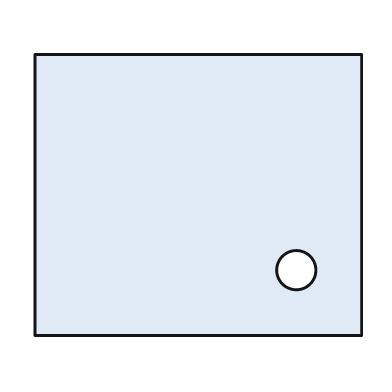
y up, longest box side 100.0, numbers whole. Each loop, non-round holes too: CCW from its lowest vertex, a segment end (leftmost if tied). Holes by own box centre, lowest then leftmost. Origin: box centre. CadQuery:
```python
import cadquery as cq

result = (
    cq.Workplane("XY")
    .moveTo(-50.0, -43.0)
    .lineTo(50.0, -43.0)
    .lineTo(50.0, 43.0)
    .lineTo(-50.0, 43.0)
    .close()
    .moveTo(30.0, -23.0)
    .circle(6.0)
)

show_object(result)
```